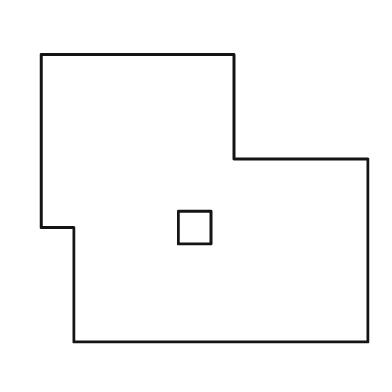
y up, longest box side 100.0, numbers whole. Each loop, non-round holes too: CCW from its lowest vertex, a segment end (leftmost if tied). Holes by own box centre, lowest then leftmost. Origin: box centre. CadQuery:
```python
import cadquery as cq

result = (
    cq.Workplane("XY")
    .moveTo(-40.0, -44.0)
    .lineTo(50.0, -44.0)
    .lineTo(50.0, 12.0)
    .lineTo(9.0, 12.0)
    .lineTo(9.0, 44.0)
    .lineTo(-50.0, 44.0)
    .lineTo(-50.0, -9.0)
    .lineTo(-40.0, -9.0)
    .close()
    .moveTo(-8.0, -14.0)
    .lineTo(2.0, -14.0)
    .lineTo(2.0, -4.0)
    .lineTo(-8.0, -4.0)
    .close()
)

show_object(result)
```